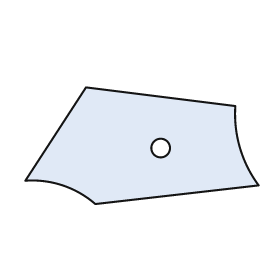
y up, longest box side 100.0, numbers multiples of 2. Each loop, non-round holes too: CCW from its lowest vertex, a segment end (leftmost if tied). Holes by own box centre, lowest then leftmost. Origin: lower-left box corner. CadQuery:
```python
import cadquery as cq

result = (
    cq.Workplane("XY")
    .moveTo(30.0, 0.0)
    .lineTo(100.0, 8.0)
    .threePointArc((92.0, 24.0), (90.0, 42.0))
    .lineTo(26.0, 50.0)
    .lineTo(0.0, 10.0)
    .threePointArc((16.0, 8.0), (30.0, 0.0))
    .close()
    .moveTo(58.0, 24.0)
    .circle(4.0)
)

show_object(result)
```